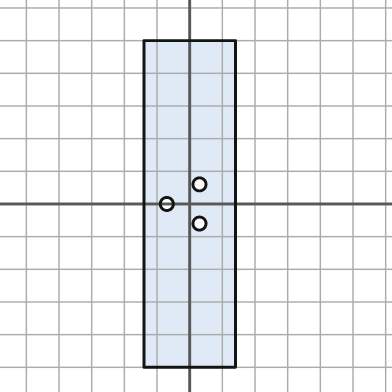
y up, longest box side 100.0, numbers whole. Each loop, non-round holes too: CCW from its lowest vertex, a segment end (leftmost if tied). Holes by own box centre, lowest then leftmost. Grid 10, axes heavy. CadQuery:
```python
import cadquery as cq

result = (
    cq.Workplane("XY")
    .moveTo(-14.0, -50.0)
    .lineTo(14.0, -50.0)
    .lineTo(14.0, 50.0)
    .lineTo(-14.0, 50.0)
    .close()
    .moveTo(3.0, -6.0)
    .circle(2.0)
    .moveTo(-7.0, 0.0)
    .circle(2.0)
    .moveTo(3.0, 6.0)
    .circle(2.0)
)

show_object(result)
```